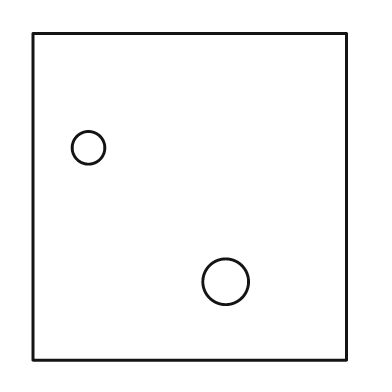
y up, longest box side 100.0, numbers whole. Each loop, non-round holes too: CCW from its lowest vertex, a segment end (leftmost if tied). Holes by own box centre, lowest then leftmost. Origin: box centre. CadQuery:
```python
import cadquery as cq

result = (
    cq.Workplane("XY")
    .moveTo(-48.0, -50.0)
    .lineTo(48.0, -50.0)
    .lineTo(48.0, 50.0)
    .lineTo(-48.0, 50.0)
    .close()
    .moveTo(11.0, -26.0)
    .circle(7.0)
    .moveTo(-31.0, 15.0)
    .circle(5.0)
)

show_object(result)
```